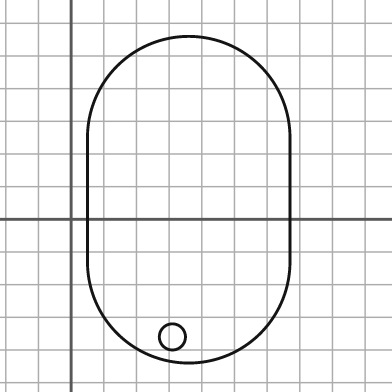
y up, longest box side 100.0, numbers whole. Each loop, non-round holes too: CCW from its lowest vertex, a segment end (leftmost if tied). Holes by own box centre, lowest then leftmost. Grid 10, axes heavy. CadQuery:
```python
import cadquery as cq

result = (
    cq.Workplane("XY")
    .moveTo(5.0, -13.0)
    .threePointArc((36.0, -44.0), (67.0, -13.0))
    .lineTo(67.0, 25.0)
    .threePointArc((36.0, 56.0), (5.0, 25.0))
    .close()
    .moveTo(31.0, -36.0)
    .circle(4.0)
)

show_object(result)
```